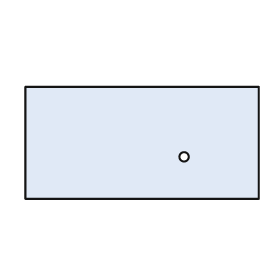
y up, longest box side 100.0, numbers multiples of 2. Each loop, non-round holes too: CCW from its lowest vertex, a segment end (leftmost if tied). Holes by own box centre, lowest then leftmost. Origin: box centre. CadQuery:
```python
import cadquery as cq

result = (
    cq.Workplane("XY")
    .moveTo(-50.0, -24.0)
    .lineTo(50.0, -24.0)
    .lineTo(50.0, 24.0)
    .lineTo(-50.0, 24.0)
    .close()
    .moveTo(18.0, -6.0)
    .circle(2.0)
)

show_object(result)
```